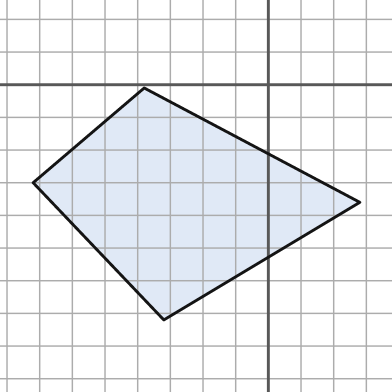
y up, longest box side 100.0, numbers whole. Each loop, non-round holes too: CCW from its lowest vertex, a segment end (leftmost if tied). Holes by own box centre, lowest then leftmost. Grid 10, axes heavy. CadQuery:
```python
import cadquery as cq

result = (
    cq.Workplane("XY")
    .moveTo(-32.0, -72.0)
    .lineTo(28.0, -36.0)
    .lineTo(-38.0, -1.0)
    .lineTo(-72.0, -30.0)
    .close()
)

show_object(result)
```